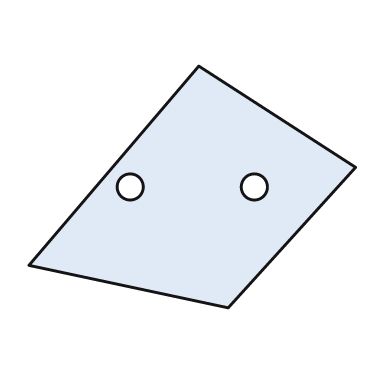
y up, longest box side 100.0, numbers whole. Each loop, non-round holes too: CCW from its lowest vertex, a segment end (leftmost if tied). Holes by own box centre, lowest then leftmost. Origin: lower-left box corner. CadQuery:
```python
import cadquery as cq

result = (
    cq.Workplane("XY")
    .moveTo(61.0, 0.0)
    .lineTo(100.0, 43.0)
    .lineTo(52.0, 74.0)
    .lineTo(0.0, 13.0)
    .close()
    .moveTo(31.0, 37.0)
    .circle(4.0)
    .moveTo(69.0, 37.0)
    .circle(4.0)
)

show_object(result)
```